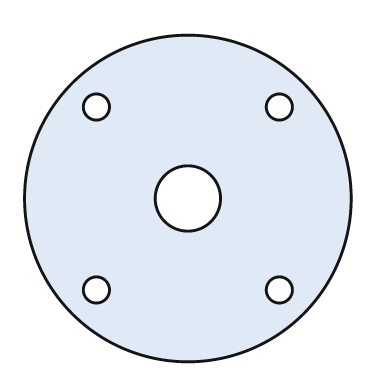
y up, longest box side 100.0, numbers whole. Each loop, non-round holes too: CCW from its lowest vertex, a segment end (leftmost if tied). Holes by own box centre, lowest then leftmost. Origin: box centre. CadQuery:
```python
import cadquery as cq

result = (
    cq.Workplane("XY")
    .moveTo(0.0, 0.0)
    .circle(50.0)
    .moveTo(-28.0, -28.0)
    .circle(4.0)
    .moveTo(28.0, -28.0)
    .circle(4.0)
    .moveTo(0.0, 0.0)
    .circle(10.0)
    .moveTo(-28.0, 28.0)
    .circle(4.0)
    .moveTo(28.0, 28.0)
    .circle(4.0)
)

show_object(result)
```